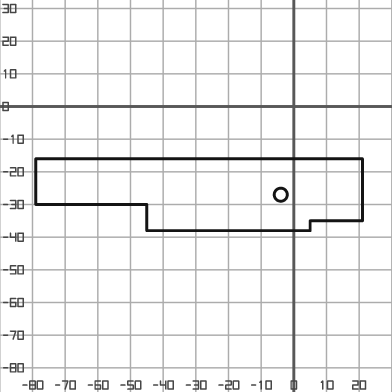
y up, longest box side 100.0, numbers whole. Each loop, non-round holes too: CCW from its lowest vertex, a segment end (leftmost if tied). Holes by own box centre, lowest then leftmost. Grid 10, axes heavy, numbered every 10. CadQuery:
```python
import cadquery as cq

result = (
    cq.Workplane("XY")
    .moveTo(-45.0, -38.0)
    .lineTo(5.0, -38.0)
    .lineTo(5.0, -35.0)
    .lineTo(21.0, -35.0)
    .lineTo(21.0, -16.0)
    .lineTo(-79.0, -16.0)
    .lineTo(-79.0, -30.0)
    .lineTo(-45.0, -30.0)
    .close()
    .moveTo(-4.0, -27.0)
    .circle(2.0)
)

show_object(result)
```